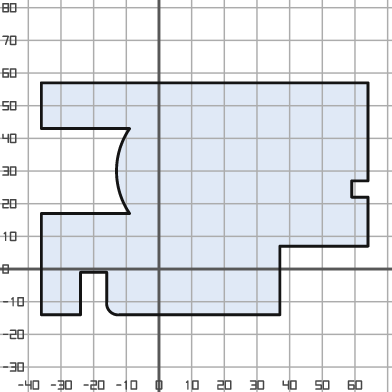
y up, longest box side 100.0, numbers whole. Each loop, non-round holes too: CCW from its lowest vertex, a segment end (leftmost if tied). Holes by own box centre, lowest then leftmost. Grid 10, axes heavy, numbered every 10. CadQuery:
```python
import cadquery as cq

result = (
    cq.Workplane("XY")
    .moveTo(-36.0, -14.0)
    .lineTo(-24.0, -14.0)
    .lineTo(-24.0, -1.0)
    .lineTo(-16.0, -1.0)
    .lineTo(-16.0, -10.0)
    .threePointArc((-15.0, -13.0), (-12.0, -14.0))
    .lineTo(37.0, -14.0)
    .lineTo(37.0, 7.0)
    .lineTo(64.0, 7.0)
    .lineTo(64.0, 22.0)
    .lineTo(59.0, 22.0)
    .lineTo(59.0, 27.0)
    .lineTo(64.0, 27.0)
    .lineTo(64.0, 57.0)
    .lineTo(-36.0, 57.0)
    .lineTo(-36.0, 43.0)
    .lineTo(-9.0, 43.0)
    .threePointArc((-13.0, 30.0), (-9.0, 17.0))
    .lineTo(-36.0, 17.0)
    .close()
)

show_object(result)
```